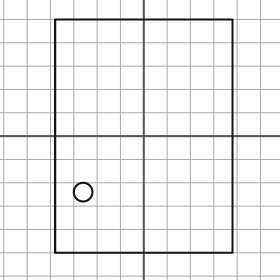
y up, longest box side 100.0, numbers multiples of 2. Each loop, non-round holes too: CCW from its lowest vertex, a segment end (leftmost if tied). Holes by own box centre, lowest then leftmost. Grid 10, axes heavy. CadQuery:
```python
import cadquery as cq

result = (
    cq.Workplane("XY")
    .moveTo(-38.0, -50.0)
    .lineTo(38.0, -50.0)
    .lineTo(38.0, 50.0)
    .lineTo(-38.0, 50.0)
    .close()
    .moveTo(-26.0, -24.0)
    .circle(4.0)
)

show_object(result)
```